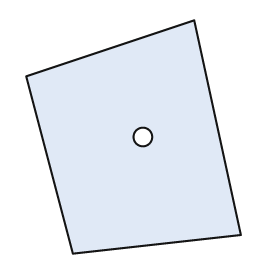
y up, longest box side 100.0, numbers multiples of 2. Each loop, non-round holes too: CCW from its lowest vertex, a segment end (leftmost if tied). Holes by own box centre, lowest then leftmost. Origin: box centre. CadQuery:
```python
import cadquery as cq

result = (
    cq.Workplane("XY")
    .moveTo(-26.0, -50.0)
    .lineTo(46.0, -42.0)
    .lineTo(26.0, 50.0)
    .lineTo(-46.0, 26.0)
    .close()
    .moveTo(4.0, 0.0)
    .circle(4.0)
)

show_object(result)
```